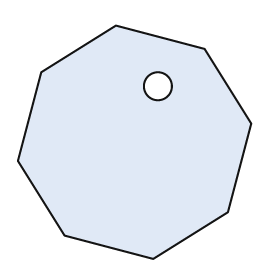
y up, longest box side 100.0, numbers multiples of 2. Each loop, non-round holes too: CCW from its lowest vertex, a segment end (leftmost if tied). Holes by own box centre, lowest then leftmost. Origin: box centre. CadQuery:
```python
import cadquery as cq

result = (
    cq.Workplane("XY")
    .moveTo(8.0, -50.0)
    .lineTo(40.0, -30.0)
    .lineTo(50.0, 8.0)
    .lineTo(30.0, 40.0)
    .lineTo(-8.0, 50.0)
    .lineTo(-40.0, 30.0)
    .lineTo(-50.0, -8.0)
    .lineTo(-30.0, -40.0)
    .close()
    .moveTo(10.0, 24.0)
    .circle(6.0)
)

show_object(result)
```